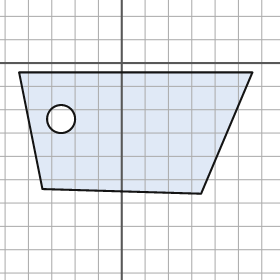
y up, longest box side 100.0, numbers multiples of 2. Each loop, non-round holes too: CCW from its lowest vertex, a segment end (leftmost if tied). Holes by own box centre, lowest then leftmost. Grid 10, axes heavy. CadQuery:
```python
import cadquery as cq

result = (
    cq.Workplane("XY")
    .moveTo(34.0, -56.0)
    .lineTo(56.0, -4.0)
    .lineTo(-44.0, -4.0)
    .lineTo(-34.0, -54.0)
    .close()
    .moveTo(-26.0, -24.0)
    .circle(6.0)
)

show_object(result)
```